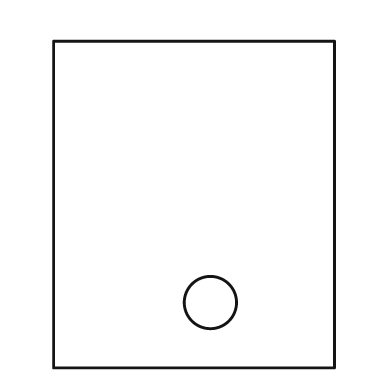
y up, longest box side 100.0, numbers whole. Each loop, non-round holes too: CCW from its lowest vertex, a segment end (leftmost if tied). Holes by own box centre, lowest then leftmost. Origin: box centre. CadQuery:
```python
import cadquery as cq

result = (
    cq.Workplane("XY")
    .moveTo(-43.0, -50.0)
    .lineTo(43.0, -50.0)
    .lineTo(43.0, 50.0)
    .lineTo(-43.0, 50.0)
    .close()
    .moveTo(5.0, -30.0)
    .circle(8.0)
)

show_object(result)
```